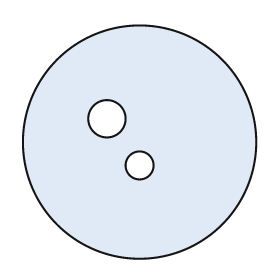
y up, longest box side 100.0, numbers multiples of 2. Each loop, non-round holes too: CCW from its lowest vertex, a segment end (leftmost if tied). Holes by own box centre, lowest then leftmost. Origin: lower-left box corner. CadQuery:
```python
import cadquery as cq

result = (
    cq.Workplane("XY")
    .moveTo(50.0, 50.0)
    .circle(50.0)
    .moveTo(50.0, 40.0)
    .circle(6.0)
    .moveTo(36.0, 60.0)
    .circle(8.0)
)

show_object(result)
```